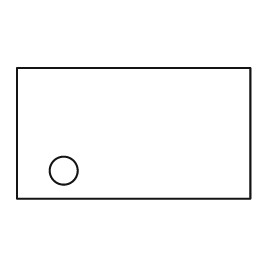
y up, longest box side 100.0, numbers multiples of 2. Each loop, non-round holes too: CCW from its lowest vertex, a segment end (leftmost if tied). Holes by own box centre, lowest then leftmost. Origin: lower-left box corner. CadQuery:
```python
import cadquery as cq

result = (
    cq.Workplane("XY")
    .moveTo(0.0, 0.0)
    .lineTo(100.0, 0.0)
    .lineTo(100.0, 56.0)
    .lineTo(0.0, 56.0)
    .close()
    .moveTo(20.0, 12.0)
    .circle(6.0)
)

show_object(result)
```